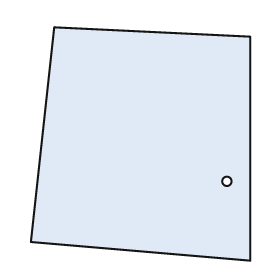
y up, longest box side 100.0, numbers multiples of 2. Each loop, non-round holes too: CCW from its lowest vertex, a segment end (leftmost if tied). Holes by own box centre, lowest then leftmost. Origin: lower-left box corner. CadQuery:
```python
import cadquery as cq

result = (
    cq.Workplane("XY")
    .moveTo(94.0, 0.0)
    .lineTo(94.0, 96.0)
    .lineTo(10.0, 100.0)
    .lineTo(0.0, 8.0)
    .close()
    .moveTo(84.0, 34.0)
    .circle(2.0)
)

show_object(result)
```